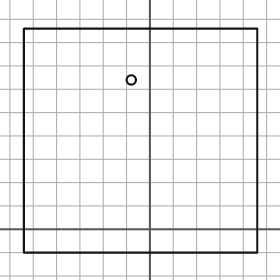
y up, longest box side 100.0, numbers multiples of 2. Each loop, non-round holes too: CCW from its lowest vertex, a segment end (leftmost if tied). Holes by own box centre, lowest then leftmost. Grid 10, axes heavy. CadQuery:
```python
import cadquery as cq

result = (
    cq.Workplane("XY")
    .moveTo(-54.0, -10.0)
    .lineTo(46.0, -10.0)
    .lineTo(46.0, 86.0)
    .lineTo(-54.0, 86.0)
    .close()
    .moveTo(-8.0, 64.0)
    .circle(2.0)
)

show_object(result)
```